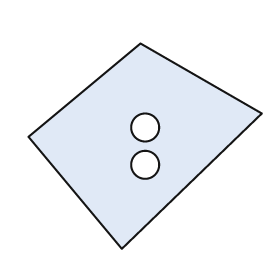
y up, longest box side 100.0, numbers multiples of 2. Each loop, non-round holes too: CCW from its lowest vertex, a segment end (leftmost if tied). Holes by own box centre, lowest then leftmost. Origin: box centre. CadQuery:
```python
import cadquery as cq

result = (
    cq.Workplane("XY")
    .moveTo(-10.0, -44.0)
    .lineTo(50.0, 14.0)
    .lineTo(-2.0, 44.0)
    .lineTo(-50.0, 4.0)
    .close()
    .moveTo(0.0, -8.0)
    .circle(6.0)
    .moveTo(0.0, 8.0)
    .circle(6.0)
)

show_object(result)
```